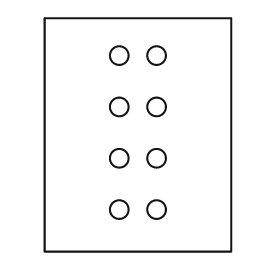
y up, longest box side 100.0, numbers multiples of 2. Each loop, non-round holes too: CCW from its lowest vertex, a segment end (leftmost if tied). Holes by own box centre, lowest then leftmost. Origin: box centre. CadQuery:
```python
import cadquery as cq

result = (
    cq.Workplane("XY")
    .moveTo(-40.0, -50.0)
    .lineTo(40.0, -50.0)
    .lineTo(40.0, 50.0)
    .lineTo(-40.0, 50.0)
    .close()
    .moveTo(-8.0, -32.0)
    .circle(4.0)
    .moveTo(8.0, -32.0)
    .circle(4.0)
    .moveTo(-8.0, -10.0)
    .circle(4.0)
    .moveTo(8.0, -10.0)
    .circle(4.0)
    .moveTo(-8.0, 12.0)
    .circle(4.0)
    .moveTo(8.0, 12.0)
    .circle(4.0)
    .moveTo(-8.0, 34.0)
    .circle(4.0)
    .moveTo(8.0, 34.0)
    .circle(4.0)
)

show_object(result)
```